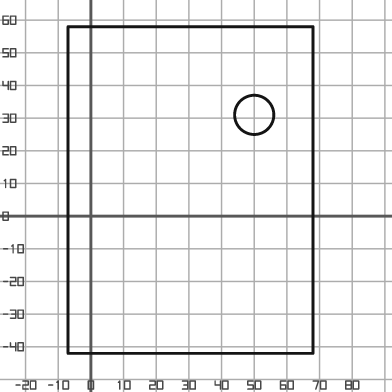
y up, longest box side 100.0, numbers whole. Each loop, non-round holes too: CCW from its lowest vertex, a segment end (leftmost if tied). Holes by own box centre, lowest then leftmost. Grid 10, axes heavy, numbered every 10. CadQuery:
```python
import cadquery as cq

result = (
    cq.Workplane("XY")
    .moveTo(-7.0, -42.0)
    .lineTo(68.0, -42.0)
    .lineTo(68.0, 58.0)
    .lineTo(-7.0, 58.0)
    .close()
    .moveTo(50.0, 31.0)
    .circle(6.0)
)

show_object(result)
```